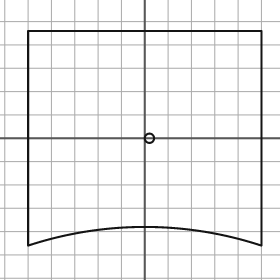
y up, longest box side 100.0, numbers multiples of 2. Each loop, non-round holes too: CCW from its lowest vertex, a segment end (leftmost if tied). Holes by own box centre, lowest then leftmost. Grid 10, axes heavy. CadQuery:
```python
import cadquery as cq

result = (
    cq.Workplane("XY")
    .moveTo(-50.0, -46.0)
    .threePointArc((0.0, -38.0), (50.0, -46.0))
    .lineTo(50.0, 46.0)
    .lineTo(-50.0, 46.0)
    .close()
    .moveTo(2.0, 0.0)
    .circle(2.0)
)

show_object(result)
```